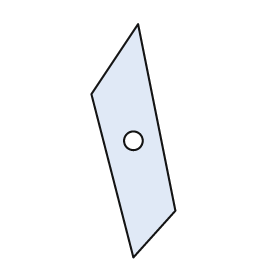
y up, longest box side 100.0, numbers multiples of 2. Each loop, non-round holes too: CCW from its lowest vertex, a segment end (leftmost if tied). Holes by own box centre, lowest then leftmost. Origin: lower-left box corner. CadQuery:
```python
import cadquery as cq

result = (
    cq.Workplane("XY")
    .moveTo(18.0, 0.0)
    .lineTo(36.0, 20.0)
    .lineTo(20.0, 100.0)
    .lineTo(0.0, 70.0)
    .close()
    .moveTo(18.0, 50.0)
    .circle(4.0)
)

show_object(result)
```